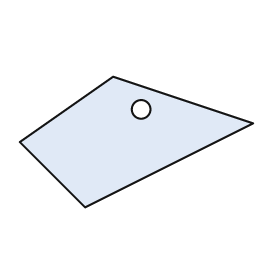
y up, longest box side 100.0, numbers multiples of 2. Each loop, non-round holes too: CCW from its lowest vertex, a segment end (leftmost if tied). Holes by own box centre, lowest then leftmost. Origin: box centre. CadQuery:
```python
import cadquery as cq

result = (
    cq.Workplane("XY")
    .moveTo(-22.0, -28.0)
    .lineTo(50.0, 8.0)
    .lineTo(-10.0, 28.0)
    .lineTo(-50.0, 0.0)
    .close()
    .moveTo(2.0, 14.0)
    .circle(4.0)
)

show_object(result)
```